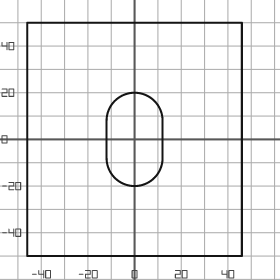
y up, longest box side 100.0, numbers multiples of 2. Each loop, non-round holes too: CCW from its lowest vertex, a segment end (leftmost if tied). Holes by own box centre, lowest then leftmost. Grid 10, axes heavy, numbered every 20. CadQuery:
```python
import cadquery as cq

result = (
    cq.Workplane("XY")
    .moveTo(-46.0, -50.0)
    .lineTo(46.0, -50.0)
    .lineTo(46.0, 50.0)
    .lineTo(-46.0, 50.0)
    .close()
    .moveTo(-12.0, -8.0)
    .threePointArc((0.0, -20.0), (12.0, -8.0))
    .lineTo(12.0, 8.0)
    .threePointArc((0.0, 20.0), (-12.0, 8.0))
    .close()
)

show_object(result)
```